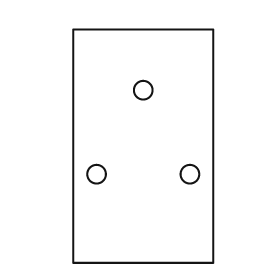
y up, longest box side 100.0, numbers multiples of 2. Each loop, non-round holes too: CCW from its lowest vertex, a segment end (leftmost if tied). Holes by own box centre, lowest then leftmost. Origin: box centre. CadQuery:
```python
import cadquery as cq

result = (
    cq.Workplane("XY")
    .moveTo(-30.0, -50.0)
    .lineTo(30.0, -50.0)
    .lineTo(30.0, 50.0)
    .lineTo(-30.0, 50.0)
    .close()
    .moveTo(-20.0, -12.0)
    .circle(4.0)
    .moveTo(20.0, -12.0)
    .circle(4.0)
    .moveTo(0.0, 24.0)
    .circle(4.0)
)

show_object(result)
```